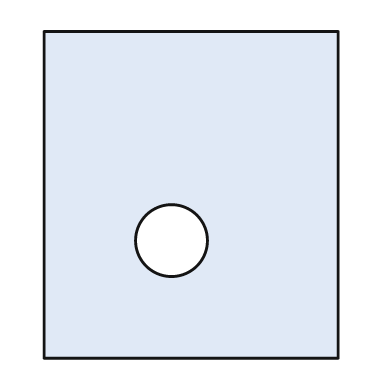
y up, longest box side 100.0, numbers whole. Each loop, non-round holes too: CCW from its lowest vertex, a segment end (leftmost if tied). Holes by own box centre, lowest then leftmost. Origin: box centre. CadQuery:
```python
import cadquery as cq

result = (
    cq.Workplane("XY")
    .moveTo(-45.0, -50.0)
    .lineTo(45.0, -50.0)
    .lineTo(45.0, 50.0)
    .lineTo(-45.0, 50.0)
    .close()
    .moveTo(-6.0, -14.0)
    .circle(11.0)
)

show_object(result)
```